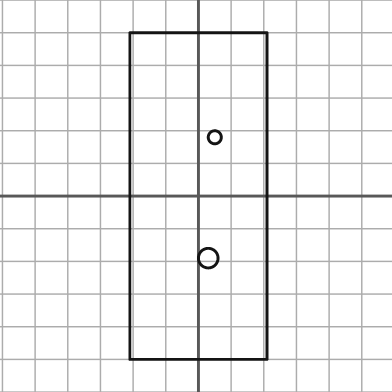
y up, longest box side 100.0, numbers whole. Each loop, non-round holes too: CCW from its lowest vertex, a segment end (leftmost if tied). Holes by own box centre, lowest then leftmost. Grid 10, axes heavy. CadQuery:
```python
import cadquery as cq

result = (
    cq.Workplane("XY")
    .moveTo(-21.0, -50.0)
    .lineTo(21.0, -50.0)
    .lineTo(21.0, 50.0)
    .lineTo(-21.0, 50.0)
    .close()
    .moveTo(3.0, -19.0)
    .circle(3.0)
    .moveTo(5.0, 18.0)
    .circle(2.0)
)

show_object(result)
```